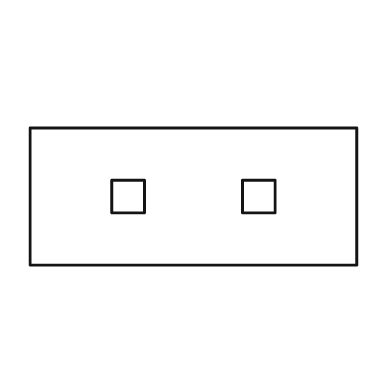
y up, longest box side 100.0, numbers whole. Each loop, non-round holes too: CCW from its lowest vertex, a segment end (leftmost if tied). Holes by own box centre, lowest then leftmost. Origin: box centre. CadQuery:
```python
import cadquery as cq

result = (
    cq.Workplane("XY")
    .moveTo(-50.0, -21.0)
    .lineTo(50.0, -21.0)
    .lineTo(50.0, 21.0)
    .lineTo(-50.0, 21.0)
    .close()
    .moveTo(-25.0, -5.0)
    .lineTo(-15.0, -5.0)
    .lineTo(-15.0, 5.0)
    .lineTo(-25.0, 5.0)
    .close()
    .moveTo(15.0, -5.0)
    .lineTo(25.0, -5.0)
    .lineTo(25.0, 5.0)
    .lineTo(15.0, 5.0)
    .close()
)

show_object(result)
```